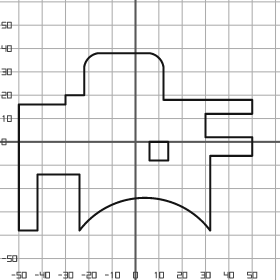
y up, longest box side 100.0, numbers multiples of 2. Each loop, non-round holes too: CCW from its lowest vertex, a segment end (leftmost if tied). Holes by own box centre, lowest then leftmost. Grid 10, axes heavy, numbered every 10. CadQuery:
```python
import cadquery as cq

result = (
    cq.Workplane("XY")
    .moveTo(-50.0, -38.0)
    .lineTo(-42.0, -38.0)
    .lineTo(-42.0, -14.0)
    .lineTo(-24.0, -14.0)
    .lineTo(-24.0, -38.0)
    .threePointArc((4.0, -24.0), (32.0, -38.0))
    .lineTo(32.0, -6.0)
    .lineTo(50.0, -6.0)
    .lineTo(50.0, 2.0)
    .lineTo(30.0, 2.0)
    .lineTo(30.0, 12.0)
    .lineTo(50.0, 12.0)
    .lineTo(50.0, 18.0)
    .lineTo(12.0, 18.0)
    .lineTo(12.0, 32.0)
    .threePointArc((10.0, 36.0), (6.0, 38.0))
    .lineTo(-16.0, 38.0)
    .threePointArc((-20.0, 36.0), (-22.0, 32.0))
    .lineTo(-22.0, 20.0)
    .lineTo(-30.0, 20.0)
    .lineTo(-30.0, 16.0)
    .lineTo(-50.0, 16.0)
    .close()
    .moveTo(6.0, -8.0)
    .lineTo(14.0, -8.0)
    .lineTo(14.0, 0.0)
    .lineTo(6.0, 0.0)
    .close()
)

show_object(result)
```